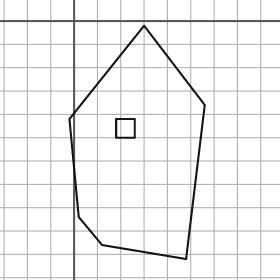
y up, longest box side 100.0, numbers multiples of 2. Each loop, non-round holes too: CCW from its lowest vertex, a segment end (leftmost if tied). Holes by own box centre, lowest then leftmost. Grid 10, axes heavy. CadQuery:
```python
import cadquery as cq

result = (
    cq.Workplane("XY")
    .moveTo(48.0, -102.0)
    .lineTo(56.0, -36.0)
    .lineTo(30.0, -2.0)
    .lineTo(-2.0, -42.0)
    .lineTo(2.0, -84.0)
    .lineTo(12.0, -96.0)
    .close()
    .moveTo(18.0, -50.0)
    .lineTo(26.0, -50.0)
    .lineTo(26.0, -42.0)
    .lineTo(18.0, -42.0)
    .close()
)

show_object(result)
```